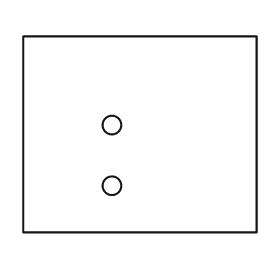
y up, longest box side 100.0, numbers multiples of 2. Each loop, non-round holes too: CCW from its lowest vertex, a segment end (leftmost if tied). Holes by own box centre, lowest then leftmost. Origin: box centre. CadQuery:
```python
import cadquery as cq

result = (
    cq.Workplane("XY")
    .moveTo(-50.0, -42.0)
    .lineTo(50.0, -42.0)
    .lineTo(50.0, 42.0)
    .lineTo(-50.0, 42.0)
    .close()
    .moveTo(-12.0, -22.0)
    .circle(4.0)
    .moveTo(-12.0, 4.0)
    .circle(4.0)
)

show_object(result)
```